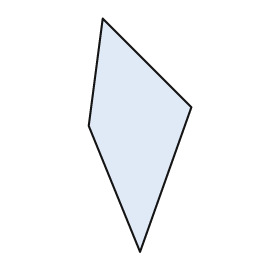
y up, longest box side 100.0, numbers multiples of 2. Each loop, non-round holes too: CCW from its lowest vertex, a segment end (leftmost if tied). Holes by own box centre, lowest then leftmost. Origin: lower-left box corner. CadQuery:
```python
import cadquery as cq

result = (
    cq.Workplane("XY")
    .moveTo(22.0, 0.0)
    .lineTo(44.0, 62.0)
    .lineTo(6.0, 100.0)
    .lineTo(0.0, 54.0)
    .close()
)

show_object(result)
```